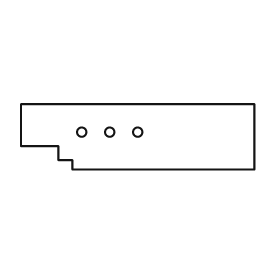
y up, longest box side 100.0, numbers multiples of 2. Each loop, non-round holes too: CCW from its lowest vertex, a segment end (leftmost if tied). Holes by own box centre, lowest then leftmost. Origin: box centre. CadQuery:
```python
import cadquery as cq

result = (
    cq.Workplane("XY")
    .moveTo(-28.0, -14.0)
    .lineTo(50.0, -14.0)
    .lineTo(50.0, 14.0)
    .lineTo(-50.0, 14.0)
    .lineTo(-50.0, -4.0)
    .lineTo(-34.0, -4.0)
    .lineTo(-34.0, -10.0)
    .lineTo(-28.0, -10.0)
    .close()
    .moveTo(-24.0, 2.0)
    .circle(2.0)
    .moveTo(-12.0, 2.0)
    .circle(2.0)
    .moveTo(0.0, 2.0)
    .circle(2.0)
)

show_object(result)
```